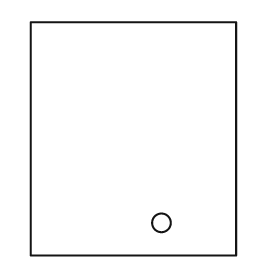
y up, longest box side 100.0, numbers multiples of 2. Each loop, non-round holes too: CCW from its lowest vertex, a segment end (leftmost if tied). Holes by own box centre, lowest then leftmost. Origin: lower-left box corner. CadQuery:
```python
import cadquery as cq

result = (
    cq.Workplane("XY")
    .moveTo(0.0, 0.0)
    .lineTo(88.0, 0.0)
    .lineTo(88.0, 100.0)
    .lineTo(0.0, 100.0)
    .close()
    .moveTo(56.0, 14.0)
    .circle(4.0)
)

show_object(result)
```